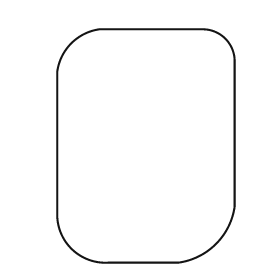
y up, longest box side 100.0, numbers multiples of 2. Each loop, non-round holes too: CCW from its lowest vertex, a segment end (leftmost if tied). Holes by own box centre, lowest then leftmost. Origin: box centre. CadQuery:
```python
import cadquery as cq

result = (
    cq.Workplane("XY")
    .moveTo(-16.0, -50.0)
    .lineTo(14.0, -50.0)
    .threePointArc((30.0, -42.0), (38.0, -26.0))
    .lineTo(38.0, 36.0)
    .threePointArc((34.0, 46.0), (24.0, 50.0))
    .lineTo(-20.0, 50.0)
    .threePointArc((-32.0, 44.0), (-38.0, 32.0))
    .lineTo(-38.0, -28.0)
    .threePointArc((-32.0, -44.0), (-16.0, -50.0))
    .close()
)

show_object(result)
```